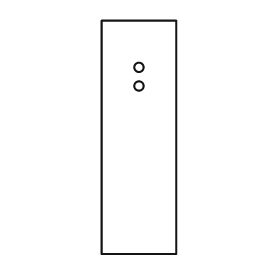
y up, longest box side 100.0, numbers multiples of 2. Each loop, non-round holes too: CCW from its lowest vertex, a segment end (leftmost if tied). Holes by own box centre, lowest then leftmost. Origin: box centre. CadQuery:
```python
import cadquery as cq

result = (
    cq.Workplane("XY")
    .moveTo(-16.0, -50.0)
    .lineTo(16.0, -50.0)
    .lineTo(16.0, 50.0)
    .lineTo(-16.0, 50.0)
    .close()
    .moveTo(0.0, 22.0)
    .circle(2.0)
    .moveTo(0.0, 30.0)
    .circle(2.0)
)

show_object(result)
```